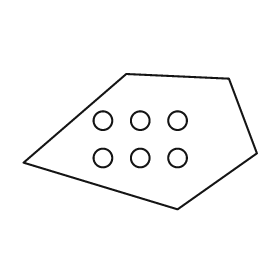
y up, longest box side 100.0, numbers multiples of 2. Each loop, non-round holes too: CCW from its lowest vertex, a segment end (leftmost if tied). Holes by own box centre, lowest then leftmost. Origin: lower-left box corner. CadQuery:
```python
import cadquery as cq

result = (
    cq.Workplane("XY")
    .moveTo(66.0, 0.0)
    .lineTo(100.0, 24.0)
    .lineTo(88.0, 56.0)
    .lineTo(44.0, 58.0)
    .lineTo(0.0, 20.0)
    .close()
    .moveTo(34.0, 22.0)
    .circle(4.0)
    .moveTo(50.0, 22.0)
    .circle(4.0)
    .moveTo(66.0, 22.0)
    .circle(4.0)
    .moveTo(34.0, 38.0)
    .circle(4.0)
    .moveTo(50.0, 38.0)
    .circle(4.0)
    .moveTo(66.0, 38.0)
    .circle(4.0)
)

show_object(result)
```